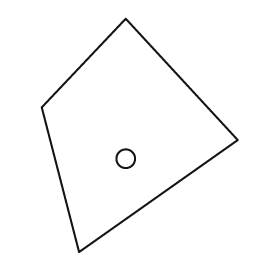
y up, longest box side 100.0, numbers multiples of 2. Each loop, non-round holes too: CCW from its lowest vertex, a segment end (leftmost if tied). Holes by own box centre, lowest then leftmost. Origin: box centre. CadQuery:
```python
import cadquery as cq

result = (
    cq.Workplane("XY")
    .moveTo(-26.0, -50.0)
    .lineTo(42.0, -2.0)
    .lineTo(-6.0, 50.0)
    .lineTo(-42.0, 12.0)
    .close()
    .moveTo(-6.0, -10.0)
    .circle(4.0)
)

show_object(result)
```